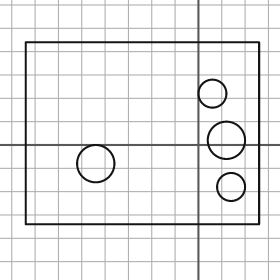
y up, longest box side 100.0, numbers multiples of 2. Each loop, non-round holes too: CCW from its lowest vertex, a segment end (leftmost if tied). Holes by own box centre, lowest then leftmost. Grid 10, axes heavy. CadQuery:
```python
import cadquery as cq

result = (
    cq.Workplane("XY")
    .moveTo(-74.0, -34.0)
    .lineTo(26.0, -34.0)
    .lineTo(26.0, 44.0)
    .lineTo(-74.0, 44.0)
    .close()
    .moveTo(14.0, -18.0)
    .circle(6.0)
    .moveTo(-44.0, -8.0)
    .circle(8.0)
    .moveTo(12.0, 2.0)
    .circle(8.0)
    .moveTo(6.0, 22.0)
    .circle(6.0)
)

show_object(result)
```